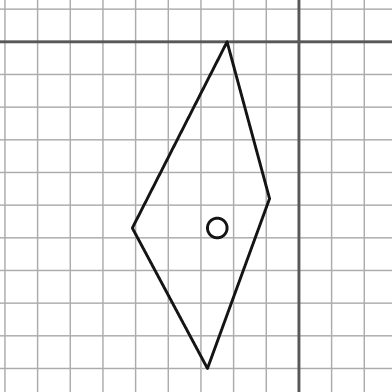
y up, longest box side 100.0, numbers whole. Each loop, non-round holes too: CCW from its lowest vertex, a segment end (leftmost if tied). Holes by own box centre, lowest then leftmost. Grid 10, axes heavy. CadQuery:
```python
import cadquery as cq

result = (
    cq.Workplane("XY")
    .moveTo(-28.0, -100.0)
    .lineTo(-9.0, -48.0)
    .lineTo(-22.0, 0.0)
    .lineTo(-51.0, -57.0)
    .close()
    .moveTo(-25.0, -57.0)
    .circle(3.0)
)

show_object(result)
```